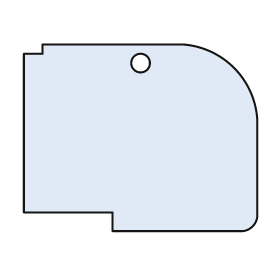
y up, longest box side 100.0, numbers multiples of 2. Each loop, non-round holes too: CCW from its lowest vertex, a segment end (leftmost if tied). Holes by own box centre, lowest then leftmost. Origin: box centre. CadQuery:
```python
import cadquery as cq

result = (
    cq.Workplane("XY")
    .moveTo(-12.0, -40.0)
    .lineTo(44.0, -40.0)
    .threePointArc((48.0, -38.0), (50.0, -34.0))
    .lineTo(50.0, 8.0)
    .threePointArc((40.0, 30.0), (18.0, 40.0))
    .lineTo(-42.0, 40.0)
    .lineTo(-42.0, 36.0)
    .lineTo(-50.0, 36.0)
    .lineTo(-50.0, -32.0)
    .lineTo(-12.0, -32.0)
    .close()
    .moveTo(0.0, 32.0)
    .circle(4.0)
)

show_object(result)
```